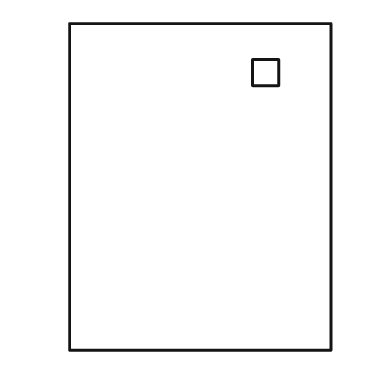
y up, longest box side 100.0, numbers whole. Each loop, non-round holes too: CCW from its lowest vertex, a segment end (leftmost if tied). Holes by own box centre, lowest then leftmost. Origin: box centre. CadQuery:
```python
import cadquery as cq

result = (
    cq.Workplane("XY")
    .moveTo(-40.0, -50.0)
    .lineTo(40.0, -50.0)
    .lineTo(40.0, 50.0)
    .lineTo(-40.0, 50.0)
    .close()
    .moveTo(16.0, 31.0)
    .lineTo(24.0, 31.0)
    .lineTo(24.0, 39.0)
    .lineTo(16.0, 39.0)
    .close()
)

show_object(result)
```